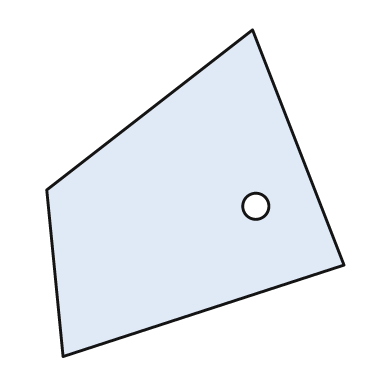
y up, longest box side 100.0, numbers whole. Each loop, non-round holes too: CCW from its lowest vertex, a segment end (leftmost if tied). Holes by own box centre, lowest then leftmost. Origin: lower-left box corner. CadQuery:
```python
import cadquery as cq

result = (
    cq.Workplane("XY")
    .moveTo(5.0, 0.0)
    .lineTo(91.0, 28.0)
    .lineTo(63.0, 100.0)
    .lineTo(0.0, 51.0)
    .close()
    .moveTo(64.0, 46.0)
    .circle(4.0)
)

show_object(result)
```